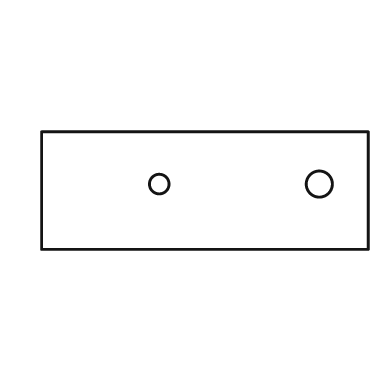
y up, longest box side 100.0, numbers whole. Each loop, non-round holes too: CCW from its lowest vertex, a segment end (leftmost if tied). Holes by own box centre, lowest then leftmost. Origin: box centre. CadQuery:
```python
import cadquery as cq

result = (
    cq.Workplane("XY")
    .moveTo(-50.0, -18.0)
    .lineTo(50.0, -18.0)
    .lineTo(50.0, 18.0)
    .lineTo(-50.0, 18.0)
    .close()
    .moveTo(-14.0, 2.0)
    .circle(3.0)
    .moveTo(35.0, 2.0)
    .circle(4.0)
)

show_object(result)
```